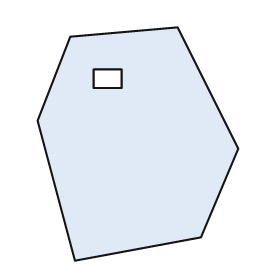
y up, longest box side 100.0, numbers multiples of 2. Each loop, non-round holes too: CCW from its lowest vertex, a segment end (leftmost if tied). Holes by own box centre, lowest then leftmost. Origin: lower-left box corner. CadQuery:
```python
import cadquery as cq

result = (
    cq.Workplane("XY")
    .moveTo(16.0, 0.0)
    .lineTo(70.0, 10.0)
    .lineTo(86.0, 48.0)
    .lineTo(60.0, 100.0)
    .lineTo(14.0, 96.0)
    .lineTo(0.0, 60.0)
    .close()
    .moveTo(24.0, 74.0)
    .lineTo(36.0, 74.0)
    .lineTo(36.0, 82.0)
    .lineTo(24.0, 82.0)
    .close()
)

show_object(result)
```